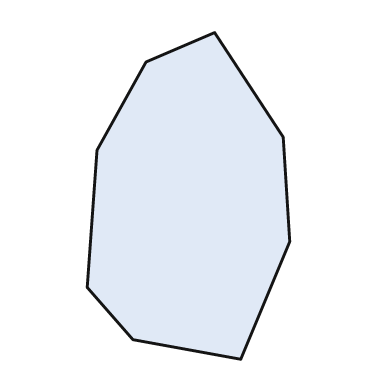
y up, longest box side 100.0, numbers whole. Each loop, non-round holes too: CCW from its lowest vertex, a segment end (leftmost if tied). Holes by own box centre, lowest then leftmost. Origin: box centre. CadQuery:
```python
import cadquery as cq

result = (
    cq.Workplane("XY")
    .moveTo(16.0, -50.0)
    .lineTo(31.0, -14.0)
    .lineTo(29.0, 18.0)
    .lineTo(8.0, 50.0)
    .lineTo(-13.0, 41.0)
    .lineTo(-28.0, 14.0)
    .lineTo(-31.0, -28.0)
    .lineTo(-17.0, -44.0)
    .close()
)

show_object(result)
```